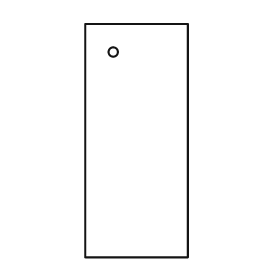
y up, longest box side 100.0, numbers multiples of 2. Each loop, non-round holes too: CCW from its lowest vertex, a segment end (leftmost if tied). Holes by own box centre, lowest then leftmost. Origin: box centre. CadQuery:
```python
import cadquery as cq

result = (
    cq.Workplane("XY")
    .moveTo(-22.0, -50.0)
    .lineTo(22.0, -50.0)
    .lineTo(22.0, 50.0)
    .lineTo(-22.0, 50.0)
    .close()
    .moveTo(-10.0, 38.0)
    .circle(2.0)
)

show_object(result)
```